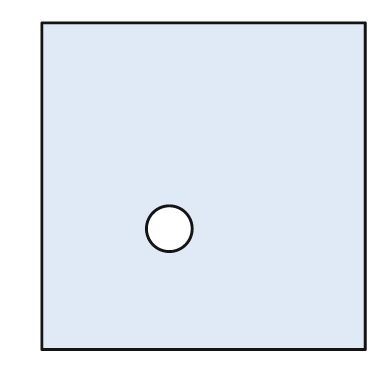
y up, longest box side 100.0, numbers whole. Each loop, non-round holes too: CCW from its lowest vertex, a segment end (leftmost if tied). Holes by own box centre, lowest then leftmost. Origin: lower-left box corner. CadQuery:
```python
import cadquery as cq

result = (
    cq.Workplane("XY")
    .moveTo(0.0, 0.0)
    .lineTo(99.0, 0.0)
    .lineTo(99.0, 100.0)
    .lineTo(0.0, 100.0)
    .close()
    .moveTo(39.0, 37.0)
    .circle(7.0)
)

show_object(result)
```